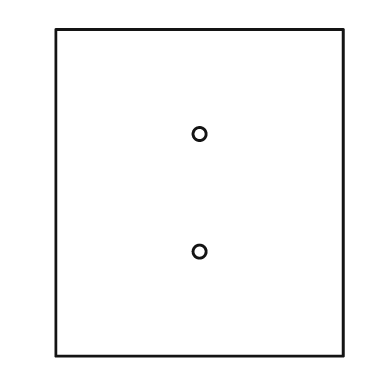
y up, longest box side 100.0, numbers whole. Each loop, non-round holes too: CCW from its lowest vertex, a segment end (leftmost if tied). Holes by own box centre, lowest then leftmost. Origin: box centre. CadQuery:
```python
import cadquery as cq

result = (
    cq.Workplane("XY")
    .moveTo(-44.0, -50.0)
    .lineTo(44.0, -50.0)
    .lineTo(44.0, 50.0)
    .lineTo(-44.0, 50.0)
    .close()
    .moveTo(0.0, -18.0)
    .circle(2.0)
    .moveTo(0.0, 18.0)
    .circle(2.0)
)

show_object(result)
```